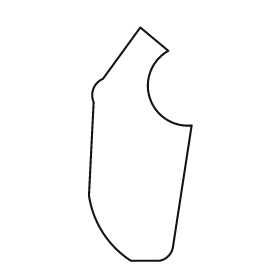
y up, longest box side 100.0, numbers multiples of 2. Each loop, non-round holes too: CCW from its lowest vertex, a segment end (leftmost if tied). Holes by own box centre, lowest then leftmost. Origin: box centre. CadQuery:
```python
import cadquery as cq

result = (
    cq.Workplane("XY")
    .moveTo(-4.0, -50.0)
    .lineTo(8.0, -50.0)
    .threePointArc((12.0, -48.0), (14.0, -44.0))
    .lineTo(22.0, 8.0)
    .threePointArc((4.0, 20.0), (12.0, 40.0))
    .lineTo(0.0, 50.0)
    .lineTo(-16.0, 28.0)
    .threePointArc((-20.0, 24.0), (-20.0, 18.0))
    .lineTo(-22.0, -22.0)
    .threePointArc((-16.0, -38.0), (-4.0, -50.0))
    .close()
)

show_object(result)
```